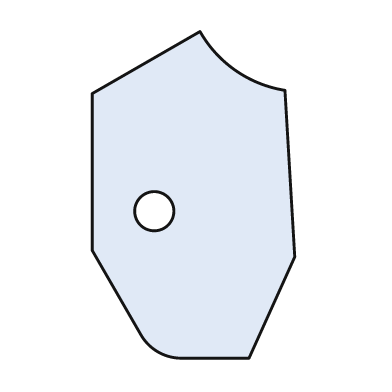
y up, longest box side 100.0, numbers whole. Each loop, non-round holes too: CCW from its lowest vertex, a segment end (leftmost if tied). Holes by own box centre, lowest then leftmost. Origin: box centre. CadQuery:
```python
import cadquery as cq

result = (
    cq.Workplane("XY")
    .moveTo(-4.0, -50.0)
    .lineTo(17.0, -50.0)
    .lineTo(31.0, -19.0)
    .lineTo(28.0, 32.0)
    .threePointArc((13.0, 38.0), (2.0, 50.0))
    .lineTo(-31.0, 31.0)
    .lineTo(-31.0, -17.0)
    .lineTo(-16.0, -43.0)
    .threePointArc((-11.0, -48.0), (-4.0, -50.0))
    .close()
    .moveTo(-12.0, -5.0)
    .circle(6.0)
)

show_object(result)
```